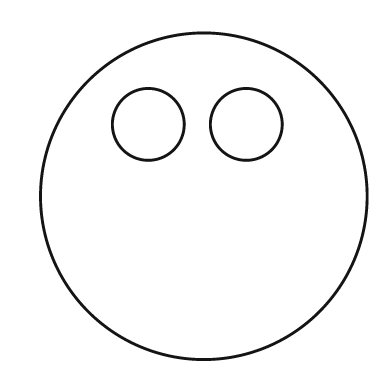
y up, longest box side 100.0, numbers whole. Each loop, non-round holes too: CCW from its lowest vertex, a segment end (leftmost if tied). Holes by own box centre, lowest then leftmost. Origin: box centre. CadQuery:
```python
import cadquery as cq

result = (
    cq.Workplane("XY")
    .moveTo(0.0, 0.0)
    .circle(50.0)
    .moveTo(-17.0, 22.0)
    .circle(11.0)
    .moveTo(13.0, 22.0)
    .circle(11.0)
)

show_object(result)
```